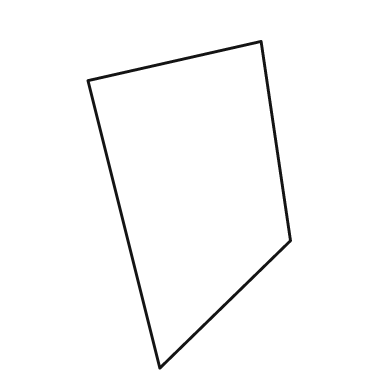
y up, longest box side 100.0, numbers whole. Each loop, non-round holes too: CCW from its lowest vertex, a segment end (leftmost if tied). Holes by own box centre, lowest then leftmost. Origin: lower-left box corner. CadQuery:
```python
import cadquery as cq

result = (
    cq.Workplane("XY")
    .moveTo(22.0, 0.0)
    .lineTo(62.0, 39.0)
    .lineTo(53.0, 100.0)
    .lineTo(0.0, 88.0)
    .close()
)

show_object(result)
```